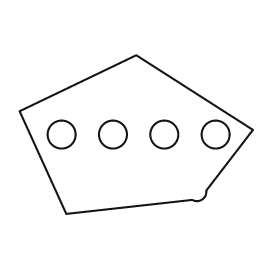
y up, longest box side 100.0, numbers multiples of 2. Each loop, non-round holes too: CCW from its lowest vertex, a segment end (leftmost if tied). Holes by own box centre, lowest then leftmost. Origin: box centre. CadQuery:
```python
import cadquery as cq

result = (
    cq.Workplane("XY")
    .moveTo(-30.0, -34.0)
    .lineTo(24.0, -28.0)
    .threePointArc((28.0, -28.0), (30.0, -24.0))
    .lineTo(50.0, 2.0)
    .lineTo(0.0, 34.0)
    .lineTo(-50.0, 10.0)
    .close()
    .moveTo(-32.0, 0.0)
    .circle(6.0)
    .moveTo(-10.0, 0.0)
    .circle(6.0)
    .moveTo(12.0, 0.0)
    .circle(6.0)
    .moveTo(34.0, 0.0)
    .circle(6.0)
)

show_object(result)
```